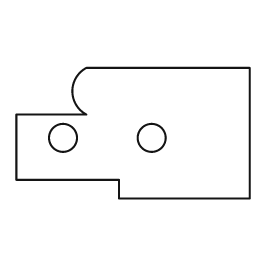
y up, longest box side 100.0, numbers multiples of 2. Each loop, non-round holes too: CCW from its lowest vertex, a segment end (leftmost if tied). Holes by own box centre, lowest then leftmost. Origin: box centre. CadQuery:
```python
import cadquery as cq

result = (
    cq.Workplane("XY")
    .moveTo(-6.0, -28.0)
    .lineTo(50.0, -28.0)
    .lineTo(50.0, 28.0)
    .lineTo(-20.0, 28.0)
    .threePointArc((-26.0, 18.0), (-20.0, 8.0))
    .lineTo(-50.0, 8.0)
    .lineTo(-50.0, -20.0)
    .lineTo(-6.0, -20.0)
    .close()
    .moveTo(-30.0, -2.0)
    .circle(6.0)
    .moveTo(8.0, -2.0)
    .circle(6.0)
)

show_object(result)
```